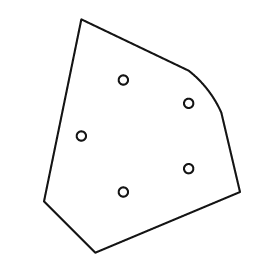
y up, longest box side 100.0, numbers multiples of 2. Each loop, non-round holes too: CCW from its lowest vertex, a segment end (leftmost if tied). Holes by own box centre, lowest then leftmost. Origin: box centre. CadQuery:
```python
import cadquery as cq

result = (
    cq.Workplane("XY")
    .moveTo(-20.0, -50.0)
    .lineTo(42.0, -24.0)
    .lineTo(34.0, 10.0)
    .threePointArc((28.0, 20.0), (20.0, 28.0))
    .lineTo(-26.0, 50.0)
    .lineTo(-42.0, -28.0)
    .close()
    .moveTo(-8.0, -24.0)
    .circle(2.0)
    .moveTo(20.0, -14.0)
    .circle(2.0)
    .moveTo(-26.0, 0.0)
    .circle(2.0)
    .moveTo(20.0, 14.0)
    .circle(2.0)
    .moveTo(-8.0, 24.0)
    .circle(2.0)
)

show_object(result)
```